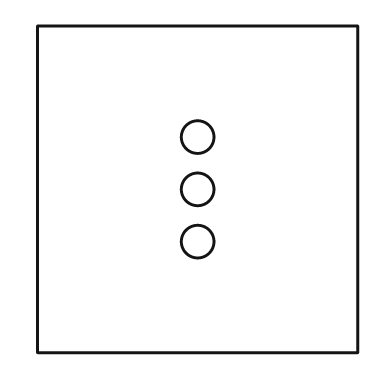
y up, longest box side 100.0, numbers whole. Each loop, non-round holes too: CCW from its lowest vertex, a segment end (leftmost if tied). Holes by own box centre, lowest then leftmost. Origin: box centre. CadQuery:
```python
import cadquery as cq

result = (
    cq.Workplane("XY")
    .moveTo(-49.0, -50.0)
    .lineTo(49.0, -50.0)
    .lineTo(49.0, 50.0)
    .lineTo(-49.0, 50.0)
    .close()
    .moveTo(0.0, -16.0)
    .circle(5.0)
    .moveTo(0.0, 0.0)
    .circle(5.0)
    .moveTo(0.0, 16.0)
    .circle(5.0)
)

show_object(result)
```